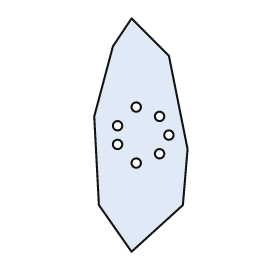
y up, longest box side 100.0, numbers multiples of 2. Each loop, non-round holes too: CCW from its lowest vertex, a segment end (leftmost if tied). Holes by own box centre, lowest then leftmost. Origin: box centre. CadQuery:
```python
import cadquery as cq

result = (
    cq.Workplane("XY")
    .moveTo(-4.0, -50.0)
    .lineTo(18.0, -30.0)
    .lineTo(20.0, -6.0)
    .lineTo(12.0, 34.0)
    .lineTo(-4.0, 50.0)
    .lineTo(-12.0, 38.0)
    .lineTo(-20.0, 8.0)
    .lineTo(-18.0, -30.0)
    .close()
    .moveTo(-2.0, -12.0)
    .circle(2.0)
    .moveTo(8.0, -8.0)
    .circle(2.0)
    .moveTo(-10.0, -4.0)
    .circle(2.0)
    .moveTo(12.0, 0.0)
    .circle(2.0)
    .moveTo(-10.0, 4.0)
    .circle(2.0)
    .moveTo(8.0, 8.0)
    .circle(2.0)
    .moveTo(-2.0, 12.0)
    .circle(2.0)
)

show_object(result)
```